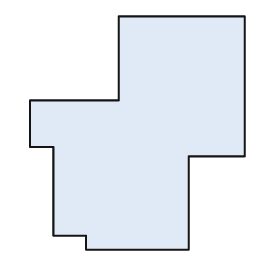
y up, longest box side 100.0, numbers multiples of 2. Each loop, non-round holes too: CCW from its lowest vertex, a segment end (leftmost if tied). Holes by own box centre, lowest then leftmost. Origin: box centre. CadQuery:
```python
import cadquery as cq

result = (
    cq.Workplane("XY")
    .moveTo(-22.0, -50.0)
    .lineTo(22.0, -50.0)
    .lineTo(22.0, -10.0)
    .lineTo(46.0, -10.0)
    .lineTo(46.0, 50.0)
    .lineTo(-8.0, 50.0)
    .lineTo(-8.0, 14.0)
    .lineTo(-46.0, 14.0)
    .lineTo(-46.0, -6.0)
    .lineTo(-36.0, -6.0)
    .lineTo(-36.0, -44.0)
    .lineTo(-22.0, -44.0)
    .close()
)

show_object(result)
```